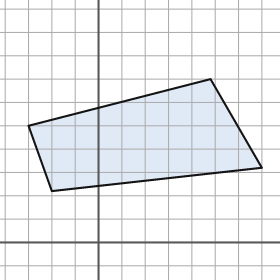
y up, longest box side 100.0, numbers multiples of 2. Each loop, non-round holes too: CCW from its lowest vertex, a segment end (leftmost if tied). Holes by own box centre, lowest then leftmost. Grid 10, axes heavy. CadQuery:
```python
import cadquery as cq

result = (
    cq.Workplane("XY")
    .moveTo(-20.0, 22.0)
    .lineTo(70.0, 32.0)
    .lineTo(48.0, 70.0)
    .lineTo(-30.0, 50.0)
    .close()
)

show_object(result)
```